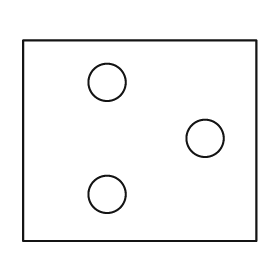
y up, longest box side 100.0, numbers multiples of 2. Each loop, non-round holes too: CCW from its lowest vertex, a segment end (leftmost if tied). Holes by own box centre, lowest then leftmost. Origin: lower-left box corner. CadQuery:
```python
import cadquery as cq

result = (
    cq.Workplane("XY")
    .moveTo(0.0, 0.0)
    .lineTo(100.0, 0.0)
    .lineTo(100.0, 86.0)
    .lineTo(0.0, 86.0)
    .close()
    .moveTo(36.0, 20.0)
    .circle(8.0)
    .moveTo(78.0, 44.0)
    .circle(8.0)
    .moveTo(36.0, 68.0)
    .circle(8.0)
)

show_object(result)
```